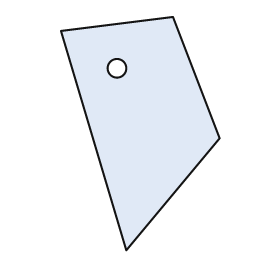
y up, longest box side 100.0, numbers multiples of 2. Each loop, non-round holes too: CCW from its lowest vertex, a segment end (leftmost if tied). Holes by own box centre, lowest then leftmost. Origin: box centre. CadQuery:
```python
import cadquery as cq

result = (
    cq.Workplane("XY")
    .moveTo(-6.0, -50.0)
    .lineTo(34.0, -2.0)
    .lineTo(14.0, 50.0)
    .lineTo(-34.0, 44.0)
    .close()
    .moveTo(-10.0, 28.0)
    .circle(4.0)
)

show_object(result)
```